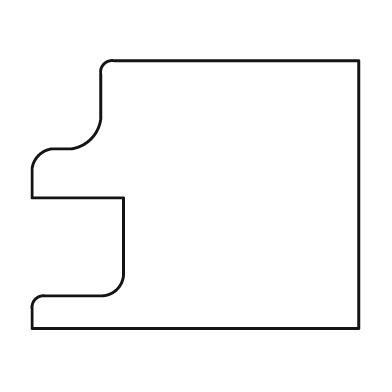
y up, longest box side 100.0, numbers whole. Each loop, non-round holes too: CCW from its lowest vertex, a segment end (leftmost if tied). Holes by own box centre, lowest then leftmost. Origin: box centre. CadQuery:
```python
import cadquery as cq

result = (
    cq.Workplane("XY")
    .moveTo(-50.0, -41.0)
    .lineTo(50.0, -41.0)
    .lineTo(50.0, 41.0)
    .lineTo(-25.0, 41.0)
    .threePointArc((-28.0, 40.0), (-29.0, 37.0))
    .lineTo(-29.0, 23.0)
    .threePointArc((-32.0, 17.0), (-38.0, 14.0))
    .lineTo(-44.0, 14.0)
    .threePointArc((-48.0, 12.0), (-50.0, 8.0))
    .lineTo(-50.0, -1.0)
    .lineTo(-22.0, -1.0)
    .lineTo(-22.0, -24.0)
    .threePointArc((-24.0, -29.0), (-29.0, -31.0))
    .lineTo(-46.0, -31.0)
    .threePointArc((-49.0, -32.0), (-50.0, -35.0))
    .close()
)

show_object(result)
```